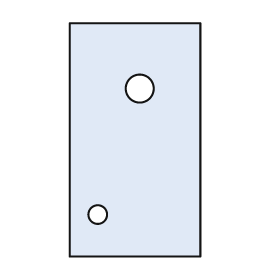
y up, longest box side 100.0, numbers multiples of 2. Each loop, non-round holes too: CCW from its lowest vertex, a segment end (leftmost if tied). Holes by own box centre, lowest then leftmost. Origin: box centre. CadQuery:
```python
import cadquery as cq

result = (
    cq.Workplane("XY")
    .moveTo(-28.0, -50.0)
    .lineTo(28.0, -50.0)
    .lineTo(28.0, 50.0)
    .lineTo(-28.0, 50.0)
    .close()
    .moveTo(-16.0, -32.0)
    .circle(4.0)
    .moveTo(2.0, 22.0)
    .circle(6.0)
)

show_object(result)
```